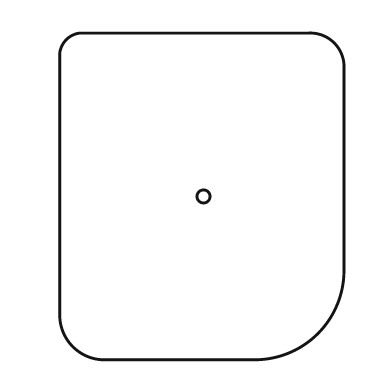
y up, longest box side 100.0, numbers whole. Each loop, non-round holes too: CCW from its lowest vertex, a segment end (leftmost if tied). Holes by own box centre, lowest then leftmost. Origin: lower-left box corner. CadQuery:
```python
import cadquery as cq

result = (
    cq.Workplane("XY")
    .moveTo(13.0, 0.0)
    .lineTo(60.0, 0.0)
    .threePointArc((79.0, 8.0), (87.0, 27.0))
    .lineTo(87.0, 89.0)
    .threePointArc((84.0, 97.0), (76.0, 100.0))
    .lineTo(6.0, 100.0)
    .threePointArc((2.0, 98.0), (0.0, 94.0))
    .lineTo(0.0, 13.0)
    .threePointArc((4.0, 4.0), (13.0, 0.0))
    .close()
    .moveTo(44.0, 50.0)
    .circle(2.0)
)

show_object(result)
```